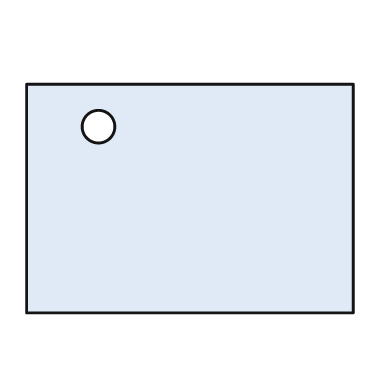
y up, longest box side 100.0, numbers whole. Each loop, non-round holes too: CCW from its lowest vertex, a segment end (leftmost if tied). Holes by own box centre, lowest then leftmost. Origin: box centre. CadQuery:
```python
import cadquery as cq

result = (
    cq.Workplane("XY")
    .moveTo(-50.0, -35.0)
    .lineTo(50.0, -35.0)
    .lineTo(50.0, 35.0)
    .lineTo(-50.0, 35.0)
    .close()
    .moveTo(-28.0, 22.0)
    .circle(5.0)
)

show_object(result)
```